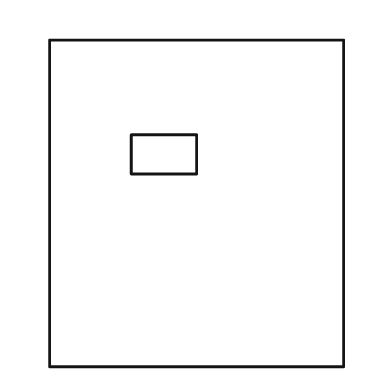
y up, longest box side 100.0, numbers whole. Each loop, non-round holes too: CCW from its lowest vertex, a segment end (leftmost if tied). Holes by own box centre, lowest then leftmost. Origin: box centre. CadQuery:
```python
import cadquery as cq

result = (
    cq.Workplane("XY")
    .moveTo(-45.0, -50.0)
    .lineTo(45.0, -50.0)
    .lineTo(45.0, 50.0)
    .lineTo(-45.0, 50.0)
    .close()
    .moveTo(-20.0, 9.0)
    .lineTo(0.0, 9.0)
    .lineTo(0.0, 21.0)
    .lineTo(-20.0, 21.0)
    .close()
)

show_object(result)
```